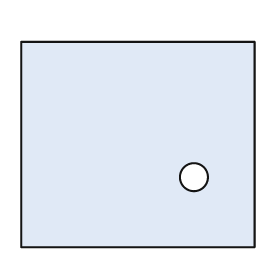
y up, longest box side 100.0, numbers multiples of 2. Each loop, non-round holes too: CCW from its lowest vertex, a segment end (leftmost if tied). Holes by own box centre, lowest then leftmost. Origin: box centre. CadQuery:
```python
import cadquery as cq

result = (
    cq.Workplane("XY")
    .moveTo(-50.0, -44.0)
    .lineTo(50.0, -44.0)
    .lineTo(50.0, 44.0)
    .lineTo(-50.0, 44.0)
    .close()
    .moveTo(24.0, -14.0)
    .circle(6.0)
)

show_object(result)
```